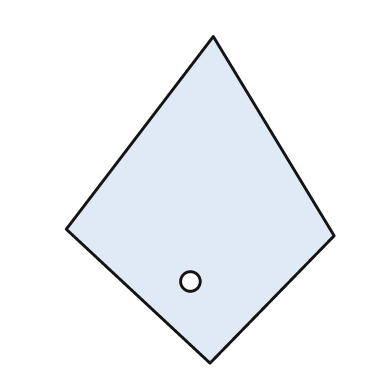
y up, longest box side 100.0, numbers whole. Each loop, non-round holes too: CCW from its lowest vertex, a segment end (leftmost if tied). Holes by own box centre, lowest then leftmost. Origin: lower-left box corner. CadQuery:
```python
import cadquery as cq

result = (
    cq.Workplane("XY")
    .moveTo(44.0, 0.0)
    .lineTo(82.0, 39.0)
    .lineTo(45.0, 100.0)
    .lineTo(0.0, 41.0)
    .close()
    .moveTo(38.0, 25.0)
    .circle(3.0)
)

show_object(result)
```